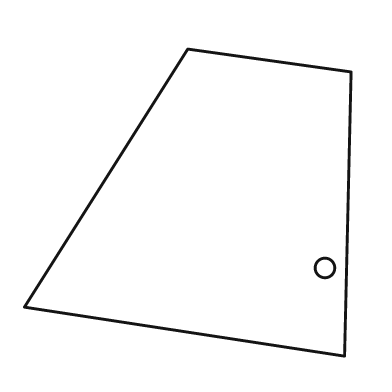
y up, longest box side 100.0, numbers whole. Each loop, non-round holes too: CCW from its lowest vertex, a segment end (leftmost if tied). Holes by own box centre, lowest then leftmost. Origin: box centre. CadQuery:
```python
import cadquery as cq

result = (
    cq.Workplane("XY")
    .moveTo(48.0, -47.0)
    .lineTo(50.0, 40.0)
    .lineTo(0.0, 47.0)
    .lineTo(-50.0, -32.0)
    .close()
    .moveTo(42.0, -20.0)
    .circle(3.0)
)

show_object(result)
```